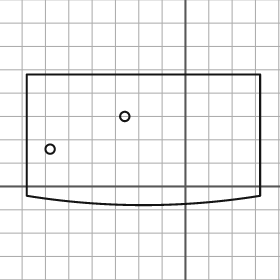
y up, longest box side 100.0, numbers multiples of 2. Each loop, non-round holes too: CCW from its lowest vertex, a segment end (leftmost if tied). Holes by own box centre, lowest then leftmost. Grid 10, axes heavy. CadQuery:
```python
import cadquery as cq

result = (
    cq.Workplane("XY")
    .moveTo(-68.0, -4.0)
    .threePointArc((-18.0, -8.0), (32.0, -4.0))
    .lineTo(32.0, 48.0)
    .lineTo(-68.0, 48.0)
    .close()
    .moveTo(-58.0, 16.0)
    .circle(2.0)
    .moveTo(-26.0, 30.0)
    .circle(2.0)
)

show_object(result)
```